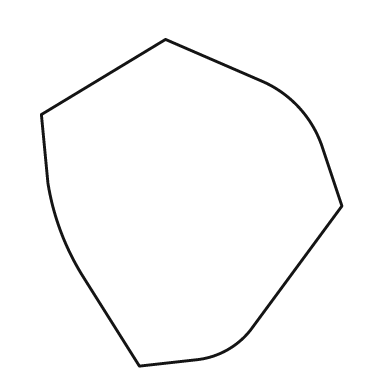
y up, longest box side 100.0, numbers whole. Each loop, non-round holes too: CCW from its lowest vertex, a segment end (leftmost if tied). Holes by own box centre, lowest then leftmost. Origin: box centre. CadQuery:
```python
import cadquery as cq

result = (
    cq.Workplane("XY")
    .moveTo(-16.0, -50.0)
    .lineTo(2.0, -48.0)
    .threePointArc((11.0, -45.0), (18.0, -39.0))
    .lineTo(46.0, -1.0)
    .lineTo(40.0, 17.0)
    .threePointArc((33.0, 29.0), (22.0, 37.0))
    .lineTo(-8.0, 50.0)
    .lineTo(-46.0, 27.0)
    .lineTo(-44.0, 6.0)
    .threePointArc((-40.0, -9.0), (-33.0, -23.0))
    .close()
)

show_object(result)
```